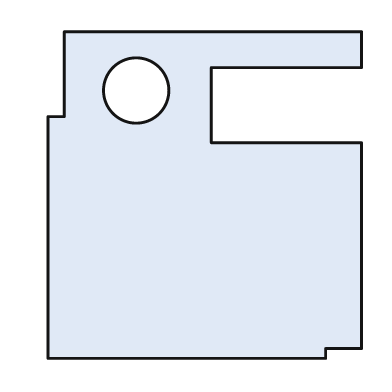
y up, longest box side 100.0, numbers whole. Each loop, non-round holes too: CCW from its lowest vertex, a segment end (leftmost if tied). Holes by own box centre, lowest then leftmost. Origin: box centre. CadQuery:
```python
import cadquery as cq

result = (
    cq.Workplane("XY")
    .moveTo(-48.0, -50.0)
    .lineTo(37.0, -50.0)
    .lineTo(37.0, -47.0)
    .lineTo(48.0, -47.0)
    .lineTo(48.0, 16.0)
    .lineTo(2.0, 16.0)
    .lineTo(2.0, 39.0)
    .lineTo(48.0, 39.0)
    .lineTo(48.0, 50.0)
    .lineTo(-43.0, 50.0)
    .lineTo(-43.0, 24.0)
    .lineTo(-48.0, 24.0)
    .close()
    .moveTo(-21.0, 32.0)
    .circle(10.0)
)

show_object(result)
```